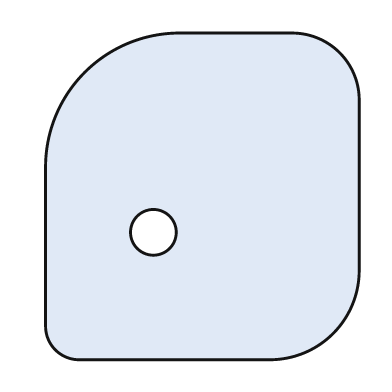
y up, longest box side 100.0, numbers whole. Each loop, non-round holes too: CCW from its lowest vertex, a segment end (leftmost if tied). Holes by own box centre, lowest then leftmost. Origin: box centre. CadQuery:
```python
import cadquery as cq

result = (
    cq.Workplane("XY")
    .moveTo(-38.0, -50.0)
    .lineTo(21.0, -50.0)
    .threePointArc((40.0, -42.0), (48.0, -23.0))
    .lineTo(48.0, 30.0)
    .threePointArc((42.0, 44.0), (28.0, 50.0))
    .lineTo(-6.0, 50.0)
    .threePointArc((-36.0, 38.0), (-48.0, 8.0))
    .lineTo(-48.0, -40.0)
    .threePointArc((-45.0, -47.0), (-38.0, -50.0))
    .close()
    .moveTo(-15.0, -11.0)
    .circle(7.0)
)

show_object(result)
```